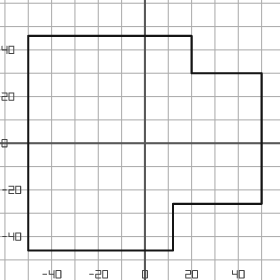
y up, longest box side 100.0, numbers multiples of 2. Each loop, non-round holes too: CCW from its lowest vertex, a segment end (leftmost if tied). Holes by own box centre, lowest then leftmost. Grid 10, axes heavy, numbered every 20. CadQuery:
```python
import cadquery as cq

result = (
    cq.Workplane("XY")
    .moveTo(-50.0, -46.0)
    .lineTo(12.0, -46.0)
    .lineTo(12.0, -26.0)
    .lineTo(50.0, -26.0)
    .lineTo(50.0, 30.0)
    .lineTo(20.0, 30.0)
    .lineTo(20.0, 46.0)
    .lineTo(-50.0, 46.0)
    .close()
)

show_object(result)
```